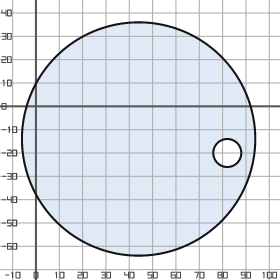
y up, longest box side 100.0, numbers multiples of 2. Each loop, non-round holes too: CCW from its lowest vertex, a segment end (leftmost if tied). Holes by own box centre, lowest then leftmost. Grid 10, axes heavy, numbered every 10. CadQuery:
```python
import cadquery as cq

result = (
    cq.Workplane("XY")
    .moveTo(44.0, -14.0)
    .circle(50.0)
    .moveTo(82.0, -20.0)
    .circle(6.0)
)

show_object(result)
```